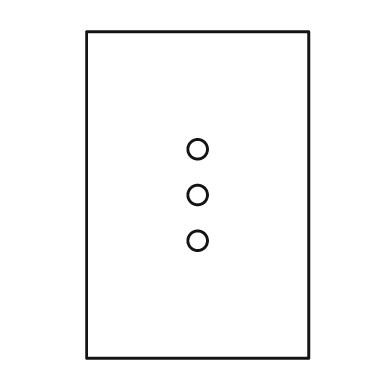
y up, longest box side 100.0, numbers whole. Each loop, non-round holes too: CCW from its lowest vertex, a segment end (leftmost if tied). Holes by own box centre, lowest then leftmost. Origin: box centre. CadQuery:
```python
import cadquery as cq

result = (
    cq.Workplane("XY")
    .moveTo(-34.0, -50.0)
    .lineTo(34.0, -50.0)
    .lineTo(34.0, 50.0)
    .lineTo(-34.0, 50.0)
    .close()
    .moveTo(0.0, -14.0)
    .circle(3.0)
    .moveTo(0.0, 0.0)
    .circle(3.0)
    .moveTo(0.0, 14.0)
    .circle(3.0)
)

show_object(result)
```